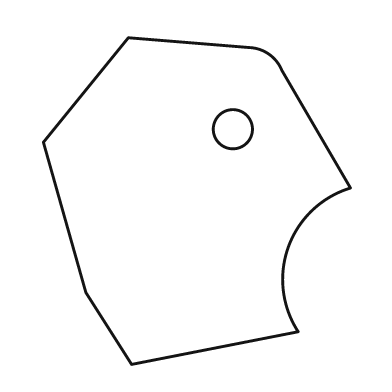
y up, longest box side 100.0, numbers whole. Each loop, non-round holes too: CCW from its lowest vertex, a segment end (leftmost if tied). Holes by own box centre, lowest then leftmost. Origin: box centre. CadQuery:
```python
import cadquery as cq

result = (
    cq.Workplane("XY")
    .moveTo(-20.0, -50.0)
    .lineTo(31.0, -40.0)
    .threePointArc((28.0, -14.0), (47.0, 4.0))
    .lineTo(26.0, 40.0)
    .threePointArc((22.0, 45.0), (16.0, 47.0))
    .lineTo(-21.0, 50.0)
    .lineTo(-47.0, 18.0)
    .lineTo(-34.0, -28.0)
    .close()
    .moveTo(11.0, 22.0)
    .circle(6.0)
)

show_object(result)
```